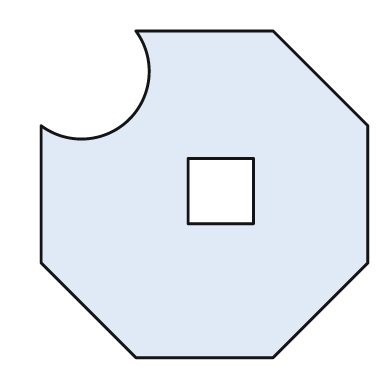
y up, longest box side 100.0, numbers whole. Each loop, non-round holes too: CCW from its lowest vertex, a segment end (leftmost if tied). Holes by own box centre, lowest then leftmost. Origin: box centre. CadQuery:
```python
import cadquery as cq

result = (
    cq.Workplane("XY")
    .moveTo(-21.0, -50.0)
    .lineTo(21.0, -50.0)
    .lineTo(50.0, -21.0)
    .lineTo(50.0, 21.0)
    .lineTo(21.0, 50.0)
    .lineTo(-21.0, 50.0)
    .threePointArc((-23.0, 23.0), (-50.0, 21.0))
    .lineTo(-50.0, -21.0)
    .close()
    .moveTo(-5.0, -9.0)
    .lineTo(15.0, -9.0)
    .lineTo(15.0, 11.0)
    .lineTo(-5.0, 11.0)
    .close()
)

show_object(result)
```